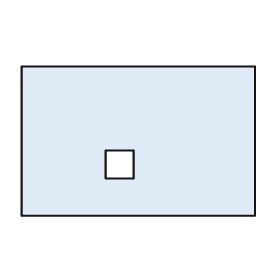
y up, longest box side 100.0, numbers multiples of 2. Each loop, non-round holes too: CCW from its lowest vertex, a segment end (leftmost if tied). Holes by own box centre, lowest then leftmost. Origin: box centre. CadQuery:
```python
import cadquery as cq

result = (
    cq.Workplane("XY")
    .moveTo(-50.0, -32.0)
    .lineTo(50.0, -32.0)
    .lineTo(50.0, 32.0)
    .lineTo(-50.0, 32.0)
    .close()
    .moveTo(-14.0, -16.0)
    .lineTo(-2.0, -16.0)
    .lineTo(-2.0, -4.0)
    .lineTo(-14.0, -4.0)
    .close()
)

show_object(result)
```